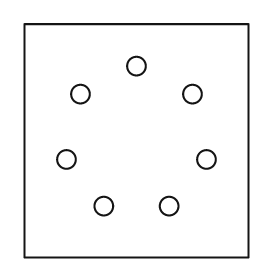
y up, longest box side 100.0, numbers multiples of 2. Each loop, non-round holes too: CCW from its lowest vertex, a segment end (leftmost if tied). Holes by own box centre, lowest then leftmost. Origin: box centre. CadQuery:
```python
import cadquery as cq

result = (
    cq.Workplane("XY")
    .moveTo(-48.0, -50.0)
    .lineTo(48.0, -50.0)
    .lineTo(48.0, 50.0)
    .lineTo(-48.0, 50.0)
    .close()
    .moveTo(-14.0, -28.0)
    .circle(4.0)
    .moveTo(14.0, -28.0)
    .circle(4.0)
    .moveTo(-30.0, -8.0)
    .circle(4.0)
    .moveTo(30.0, -8.0)
    .circle(4.0)
    .moveTo(-24.0, 20.0)
    .circle(4.0)
    .moveTo(24.0, 20.0)
    .circle(4.0)
    .moveTo(0.0, 32.0)
    .circle(4.0)
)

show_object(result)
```